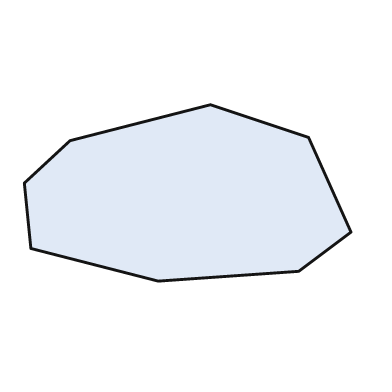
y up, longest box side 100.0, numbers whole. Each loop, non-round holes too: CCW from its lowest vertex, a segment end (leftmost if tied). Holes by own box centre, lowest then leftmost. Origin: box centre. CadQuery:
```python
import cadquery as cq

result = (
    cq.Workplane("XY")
    .moveTo(-9.0, -27.0)
    .lineTo(34.0, -24.0)
    .lineTo(50.0, -12.0)
    .lineTo(37.0, 17.0)
    .lineTo(7.0, 27.0)
    .lineTo(-36.0, 16.0)
    .lineTo(-50.0, 3.0)
    .lineTo(-48.0, -17.0)
    .close()
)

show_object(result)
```